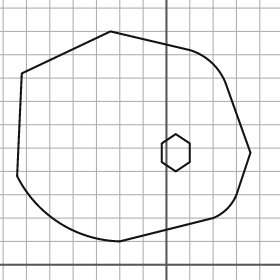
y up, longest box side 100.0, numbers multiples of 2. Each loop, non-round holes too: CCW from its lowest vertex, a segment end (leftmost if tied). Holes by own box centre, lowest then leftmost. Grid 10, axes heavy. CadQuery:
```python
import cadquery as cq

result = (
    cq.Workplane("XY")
    .moveTo(-20.0, 10.0)
    .lineTo(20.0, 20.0)
    .threePointArc((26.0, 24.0), (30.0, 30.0))
    .lineTo(36.0, 48.0)
    .lineTo(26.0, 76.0)
    .threePointArc((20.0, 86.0), (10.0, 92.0))
    .lineTo(-24.0, 100.0)
    .lineTo(-62.0, 82.0)
    .lineTo(-64.0, 38.0)
    .threePointArc((-46.0, 18.0), (-20.0, 10.0))
    .close()
    .moveTo(4.0, 40.0)
    .lineTo(10.0, 44.0)
    .lineTo(10.0, 52.0)
    .lineTo(4.0, 56.0)
    .lineTo(-2.0, 52.0)
    .lineTo(-2.0, 44.0)
    .close()
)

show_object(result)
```